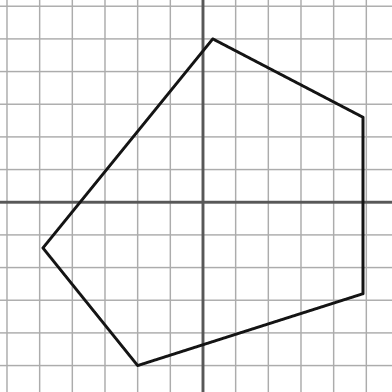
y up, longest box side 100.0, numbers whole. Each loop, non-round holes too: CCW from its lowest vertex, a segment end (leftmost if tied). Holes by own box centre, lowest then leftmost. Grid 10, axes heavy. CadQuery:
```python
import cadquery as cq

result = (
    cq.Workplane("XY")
    .moveTo(-20.0, -50.0)
    .lineTo(49.0, -28.0)
    .lineTo(49.0, 26.0)
    .lineTo(3.0, 50.0)
    .lineTo(-49.0, -14.0)
    .close()
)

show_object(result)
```